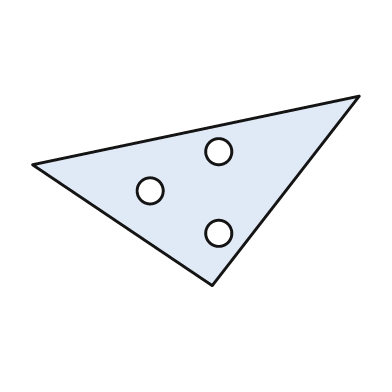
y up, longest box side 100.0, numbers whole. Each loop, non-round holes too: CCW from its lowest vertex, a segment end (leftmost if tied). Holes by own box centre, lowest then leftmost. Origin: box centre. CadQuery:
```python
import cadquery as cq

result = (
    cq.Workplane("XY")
    .moveTo(5.0, -29.0)
    .lineTo(50.0, 29.0)
    .lineTo(-50.0, 8.0)
    .close()
    .moveTo(7.0, -13.0)
    .circle(4.0)
    .moveTo(-14.0, 0.0)
    .circle(4.0)
    .moveTo(7.0, 12.0)
    .circle(4.0)
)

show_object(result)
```